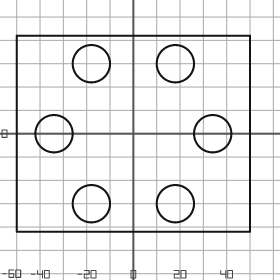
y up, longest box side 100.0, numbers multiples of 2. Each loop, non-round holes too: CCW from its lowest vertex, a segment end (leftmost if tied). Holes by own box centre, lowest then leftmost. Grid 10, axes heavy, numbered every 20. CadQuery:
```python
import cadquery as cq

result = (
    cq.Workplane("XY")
    .moveTo(-50.0, -42.0)
    .lineTo(50.0, -42.0)
    .lineTo(50.0, 42.0)
    .lineTo(-50.0, 42.0)
    .close()
    .moveTo(-18.0, -30.0)
    .circle(8.0)
    .moveTo(18.0, -30.0)
    .circle(8.0)
    .moveTo(-34.0, 0.0)
    .circle(8.0)
    .moveTo(34.0, 0.0)
    .circle(8.0)
    .moveTo(-18.0, 30.0)
    .circle(8.0)
    .moveTo(18.0, 30.0)
    .circle(8.0)
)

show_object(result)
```